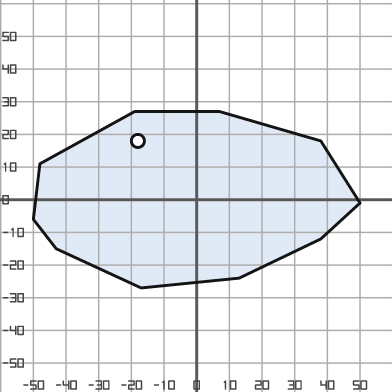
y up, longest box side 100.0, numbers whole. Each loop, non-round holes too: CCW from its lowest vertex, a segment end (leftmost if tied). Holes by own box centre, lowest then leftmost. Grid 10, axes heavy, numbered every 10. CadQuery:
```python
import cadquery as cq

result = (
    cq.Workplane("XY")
    .moveTo(-17.0, -27.0)
    .lineTo(13.0, -24.0)
    .lineTo(38.0, -12.0)
    .lineTo(50.0, -1.0)
    .lineTo(38.0, 18.0)
    .lineTo(7.0, 27.0)
    .lineTo(-19.0, 27.0)
    .lineTo(-48.0, 11.0)
    .lineTo(-50.0, -6.0)
    .lineTo(-43.0, -15.0)
    .close()
    .moveTo(-18.0, 18.0)
    .circle(2.0)
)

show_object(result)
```